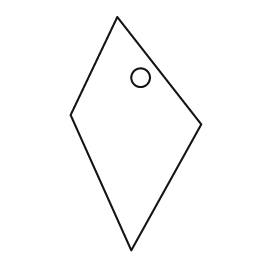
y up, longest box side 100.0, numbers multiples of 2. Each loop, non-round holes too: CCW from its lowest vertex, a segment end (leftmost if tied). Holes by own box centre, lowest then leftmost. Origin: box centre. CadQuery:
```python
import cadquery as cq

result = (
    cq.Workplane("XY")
    .moveTo(-2.0, -50.0)
    .lineTo(28.0, 4.0)
    .lineTo(-8.0, 50.0)
    .lineTo(-28.0, 8.0)
    .close()
    .moveTo(2.0, 24.0)
    .circle(4.0)
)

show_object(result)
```